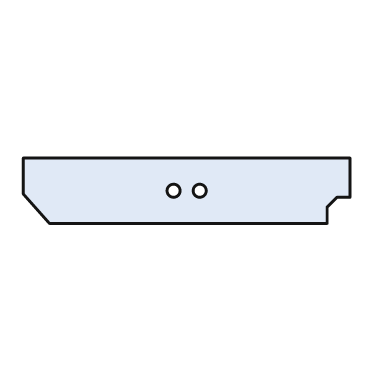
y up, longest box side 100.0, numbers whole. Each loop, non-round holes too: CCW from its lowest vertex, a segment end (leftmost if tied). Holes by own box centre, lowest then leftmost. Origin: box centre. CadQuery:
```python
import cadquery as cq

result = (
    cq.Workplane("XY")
    .moveTo(-42.0, -10.0)
    .lineTo(43.0, -10.0)
    .lineTo(43.0, -5.0)
    .lineTo(46.0, -2.0)
    .lineTo(50.0, -2.0)
    .lineTo(50.0, 10.0)
    .lineTo(-50.0, 10.0)
    .lineTo(-50.0, -1.0)
    .close()
    .moveTo(-4.0, 0.0)
    .circle(2.0)
    .moveTo(4.0, 0.0)
    .circle(2.0)
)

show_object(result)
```